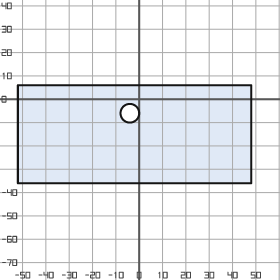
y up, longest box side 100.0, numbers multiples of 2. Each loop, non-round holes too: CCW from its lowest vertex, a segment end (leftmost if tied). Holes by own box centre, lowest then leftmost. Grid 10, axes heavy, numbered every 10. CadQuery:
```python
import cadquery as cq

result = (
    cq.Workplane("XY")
    .moveTo(-52.0, -36.0)
    .lineTo(48.0, -36.0)
    .lineTo(48.0, 6.0)
    .lineTo(-52.0, 6.0)
    .close()
    .moveTo(-4.0, -6.0)
    .circle(4.0)
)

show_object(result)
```